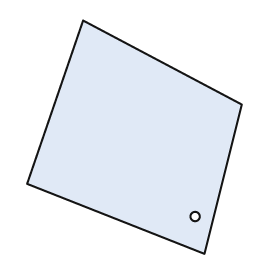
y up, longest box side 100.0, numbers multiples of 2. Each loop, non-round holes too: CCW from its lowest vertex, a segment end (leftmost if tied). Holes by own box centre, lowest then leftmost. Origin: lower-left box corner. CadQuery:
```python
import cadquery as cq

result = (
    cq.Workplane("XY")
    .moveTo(76.0, 0.0)
    .lineTo(92.0, 64.0)
    .lineTo(24.0, 100.0)
    .lineTo(0.0, 30.0)
    .close()
    .moveTo(72.0, 16.0)
    .circle(2.0)
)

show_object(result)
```